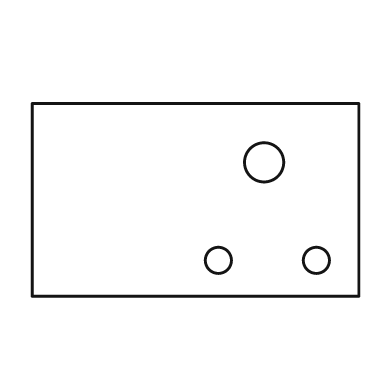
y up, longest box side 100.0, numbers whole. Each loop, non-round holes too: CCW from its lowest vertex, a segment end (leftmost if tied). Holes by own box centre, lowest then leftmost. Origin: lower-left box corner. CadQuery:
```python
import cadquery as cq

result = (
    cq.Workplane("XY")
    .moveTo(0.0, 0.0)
    .lineTo(100.0, 0.0)
    .lineTo(100.0, 59.0)
    .lineTo(0.0, 59.0)
    .close()
    .moveTo(57.0, 11.0)
    .circle(4.0)
    .moveTo(87.0, 11.0)
    .circle(4.0)
    .moveTo(71.0, 41.0)
    .circle(6.0)
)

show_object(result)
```